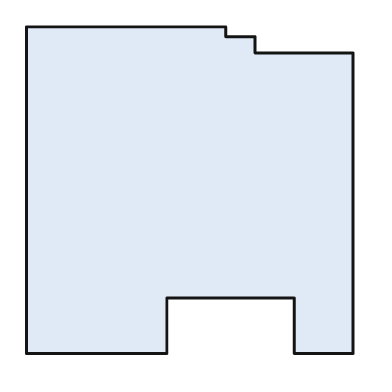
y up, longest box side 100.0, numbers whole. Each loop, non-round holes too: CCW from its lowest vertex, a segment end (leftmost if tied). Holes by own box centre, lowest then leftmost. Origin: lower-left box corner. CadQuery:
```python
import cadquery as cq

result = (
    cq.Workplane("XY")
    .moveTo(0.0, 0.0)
    .lineTo(43.0, 0.0)
    .lineTo(43.0, 17.0)
    .lineTo(82.0, 17.0)
    .lineTo(82.0, 0.0)
    .lineTo(100.0, 0.0)
    .lineTo(100.0, 92.0)
    .lineTo(70.0, 92.0)
    .lineTo(70.0, 97.0)
    .lineTo(61.0, 97.0)
    .lineTo(61.0, 100.0)
    .lineTo(0.0, 100.0)
    .close()
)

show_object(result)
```